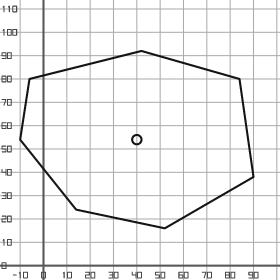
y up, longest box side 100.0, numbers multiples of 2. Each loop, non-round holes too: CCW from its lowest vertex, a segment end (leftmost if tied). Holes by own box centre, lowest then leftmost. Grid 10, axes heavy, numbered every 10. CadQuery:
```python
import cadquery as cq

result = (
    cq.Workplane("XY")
    .moveTo(52.0, 16.0)
    .lineTo(90.0, 38.0)
    .lineTo(84.0, 80.0)
    .lineTo(42.0, 92.0)
    .lineTo(-6.0, 80.0)
    .lineTo(-10.0, 54.0)
    .lineTo(14.0, 24.0)
    .close()
    .moveTo(40.0, 54.0)
    .circle(2.0)
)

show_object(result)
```